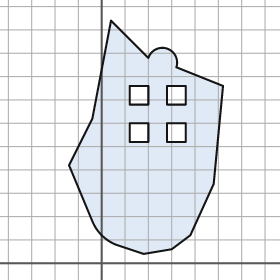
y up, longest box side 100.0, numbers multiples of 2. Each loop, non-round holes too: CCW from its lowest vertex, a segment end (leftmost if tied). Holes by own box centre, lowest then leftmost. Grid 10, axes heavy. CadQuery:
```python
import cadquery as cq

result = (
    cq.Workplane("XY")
    .moveTo(18.0, 4.0)
    .lineTo(30.0, 6.0)
    .lineTo(38.0, 12.0)
    .lineTo(48.0, 34.0)
    .lineTo(52.0, 76.0)
    .lineTo(32.0, 84.0)
    .threePointArc((28.0, 92.0), (20.0, 88.0))
    .lineTo(4.0, 104.0)
    .lineTo(-4.0, 62.0)
    .lineTo(-14.0, 42.0)
    .lineTo(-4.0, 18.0)
    .threePointArc((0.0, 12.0), (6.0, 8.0))
    .close()
    .moveTo(12.0, 52.0)
    .lineTo(20.0, 52.0)
    .lineTo(20.0, 60.0)
    .lineTo(12.0, 60.0)
    .close()
    .moveTo(28.0, 52.0)
    .lineTo(36.0, 52.0)
    .lineTo(36.0, 60.0)
    .lineTo(28.0, 60.0)
    .close()
    .moveTo(12.0, 68.0)
    .lineTo(20.0, 68.0)
    .lineTo(20.0, 76.0)
    .lineTo(12.0, 76.0)
    .close()
    .moveTo(28.0, 68.0)
    .lineTo(36.0, 68.0)
    .lineTo(36.0, 76.0)
    .lineTo(28.0, 76.0)
    .close()
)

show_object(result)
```